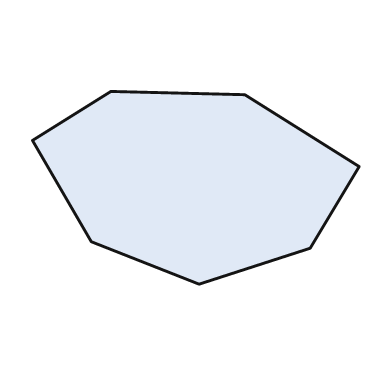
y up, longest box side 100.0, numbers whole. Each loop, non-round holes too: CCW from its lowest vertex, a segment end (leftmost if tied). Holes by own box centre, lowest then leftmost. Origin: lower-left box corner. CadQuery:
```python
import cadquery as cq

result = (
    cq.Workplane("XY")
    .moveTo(51.0, 0.0)
    .lineTo(85.0, 11.0)
    .lineTo(100.0, 36.0)
    .lineTo(65.0, 58.0)
    .lineTo(24.0, 59.0)
    .lineTo(0.0, 44.0)
    .lineTo(18.0, 13.0)
    .close()
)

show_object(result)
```